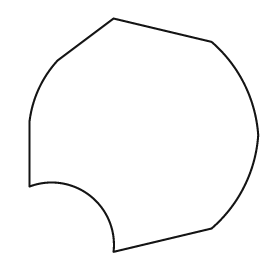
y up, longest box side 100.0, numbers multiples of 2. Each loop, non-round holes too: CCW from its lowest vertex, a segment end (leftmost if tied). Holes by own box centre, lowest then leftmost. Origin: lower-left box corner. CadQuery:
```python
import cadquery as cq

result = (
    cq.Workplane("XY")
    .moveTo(36.0, 0.0)
    .lineTo(78.0, 10.0)
    .threePointArc((92.0, 28.0), (98.0, 50.0))
    .threePointArc((92.0, 72.0), (78.0, 90.0))
    .lineTo(36.0, 100.0)
    .lineTo(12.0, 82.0)
    .threePointArc((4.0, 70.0), (0.0, 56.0))
    .lineTo(0.0, 28.0)
    .threePointArc((26.0, 24.0), (36.0, 0.0))
    .close()
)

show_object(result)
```